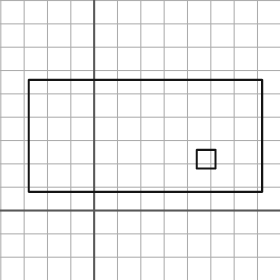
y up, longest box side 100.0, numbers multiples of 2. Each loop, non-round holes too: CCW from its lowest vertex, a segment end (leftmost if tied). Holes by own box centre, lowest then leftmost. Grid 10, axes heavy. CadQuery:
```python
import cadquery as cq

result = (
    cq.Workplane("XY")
    .moveTo(-28.0, 8.0)
    .lineTo(72.0, 8.0)
    .lineTo(72.0, 56.0)
    .lineTo(-28.0, 56.0)
    .close()
    .moveTo(44.0, 18.0)
    .lineTo(52.0, 18.0)
    .lineTo(52.0, 26.0)
    .lineTo(44.0, 26.0)
    .close()
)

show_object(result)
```